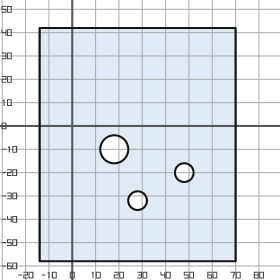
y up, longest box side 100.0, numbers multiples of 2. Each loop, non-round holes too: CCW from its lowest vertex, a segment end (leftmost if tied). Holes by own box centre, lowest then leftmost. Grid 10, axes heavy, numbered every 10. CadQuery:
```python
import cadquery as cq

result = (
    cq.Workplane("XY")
    .moveTo(-14.0, -58.0)
    .lineTo(70.0, -58.0)
    .lineTo(70.0, 42.0)
    .lineTo(-14.0, 42.0)
    .close()
    .moveTo(28.0, -32.0)
    .circle(4.0)
    .moveTo(48.0, -20.0)
    .circle(4.0)
    .moveTo(18.0, -10.0)
    .circle(6.0)
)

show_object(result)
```